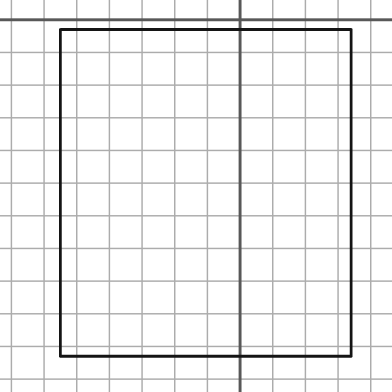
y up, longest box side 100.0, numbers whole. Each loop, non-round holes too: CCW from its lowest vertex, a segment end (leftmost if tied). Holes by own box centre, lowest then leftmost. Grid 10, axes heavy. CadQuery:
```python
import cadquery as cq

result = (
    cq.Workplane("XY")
    .moveTo(-55.0, -103.0)
    .lineTo(34.0, -103.0)
    .lineTo(34.0, -3.0)
    .lineTo(-55.0, -3.0)
    .close()
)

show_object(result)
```